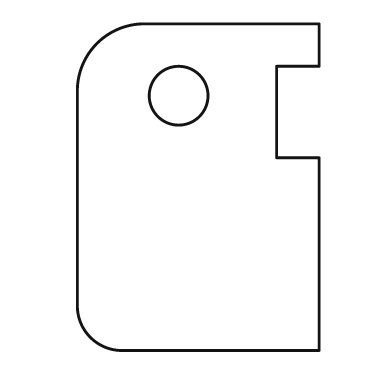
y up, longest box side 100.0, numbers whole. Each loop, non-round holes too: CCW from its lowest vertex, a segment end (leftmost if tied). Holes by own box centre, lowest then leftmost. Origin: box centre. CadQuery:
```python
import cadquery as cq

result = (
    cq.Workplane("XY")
    .moveTo(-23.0, -50.0)
    .lineTo(37.0, -50.0)
    .lineTo(37.0, 9.0)
    .lineTo(24.0, 9.0)
    .lineTo(24.0, 37.0)
    .lineTo(37.0, 37.0)
    .lineTo(37.0, 50.0)
    .lineTo(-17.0, 50.0)
    .threePointArc((-31.0, 44.0), (-37.0, 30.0))
    .lineTo(-37.0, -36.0)
    .threePointArc((-33.0, -46.0), (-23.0, -50.0))
    .close()
    .moveTo(-6.0, 28.0)
    .circle(9.0)
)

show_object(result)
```